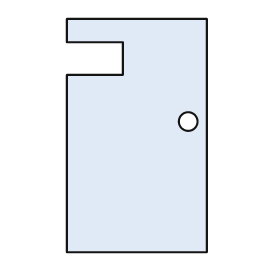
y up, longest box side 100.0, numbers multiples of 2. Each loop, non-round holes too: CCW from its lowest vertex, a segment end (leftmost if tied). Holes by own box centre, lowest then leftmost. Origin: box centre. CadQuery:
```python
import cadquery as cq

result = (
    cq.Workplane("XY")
    .moveTo(-30.0, -50.0)
    .lineTo(30.0, -50.0)
    .lineTo(30.0, 50.0)
    .lineTo(-30.0, 50.0)
    .lineTo(-30.0, 40.0)
    .lineTo(-6.0, 40.0)
    .lineTo(-6.0, 26.0)
    .lineTo(-30.0, 26.0)
    .close()
    .moveTo(22.0, 6.0)
    .circle(4.0)
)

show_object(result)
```